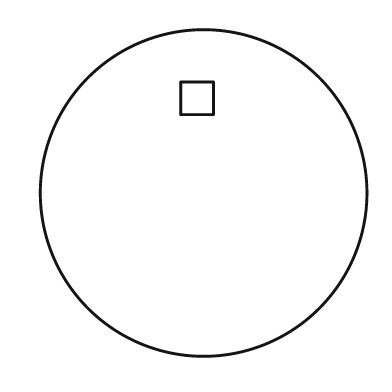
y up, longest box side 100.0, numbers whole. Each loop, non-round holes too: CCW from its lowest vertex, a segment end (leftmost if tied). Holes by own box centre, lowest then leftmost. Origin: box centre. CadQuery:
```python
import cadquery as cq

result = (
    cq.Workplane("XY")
    .moveTo(0.0, 0.0)
    .circle(50.0)
    .moveTo(-7.0, 24.0)
    .lineTo(3.0, 24.0)
    .lineTo(3.0, 34.0)
    .lineTo(-7.0, 34.0)
    .close()
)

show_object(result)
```